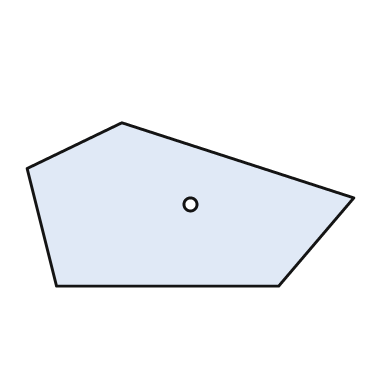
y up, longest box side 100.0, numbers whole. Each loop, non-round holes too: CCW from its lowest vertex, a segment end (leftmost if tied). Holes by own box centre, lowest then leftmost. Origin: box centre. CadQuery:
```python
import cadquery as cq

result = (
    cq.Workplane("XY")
    .moveTo(-41.0, -25.0)
    .lineTo(27.0, -25.0)
    .lineTo(50.0, 2.0)
    .lineTo(-21.0, 25.0)
    .lineTo(-50.0, 11.0)
    .close()
    .moveTo(0.0, 0.0)
    .circle(2.0)
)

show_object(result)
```